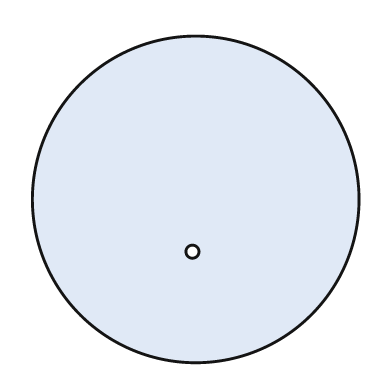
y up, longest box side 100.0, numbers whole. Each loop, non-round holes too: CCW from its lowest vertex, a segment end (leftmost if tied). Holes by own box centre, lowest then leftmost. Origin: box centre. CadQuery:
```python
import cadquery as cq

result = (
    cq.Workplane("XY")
    .moveTo(0.0, 0.0)
    .circle(50.0)
    .moveTo(-1.0, -16.0)
    .circle(2.0)
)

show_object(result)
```